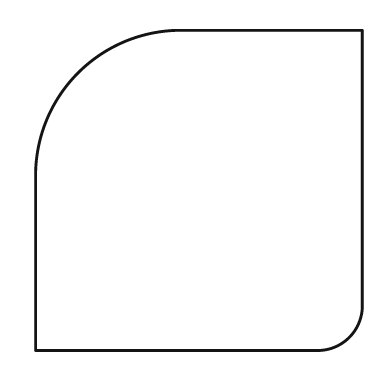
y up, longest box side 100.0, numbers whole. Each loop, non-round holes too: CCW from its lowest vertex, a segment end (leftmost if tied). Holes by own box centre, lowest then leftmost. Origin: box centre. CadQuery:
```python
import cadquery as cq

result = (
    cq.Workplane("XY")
    .moveTo(-50.0, -49.0)
    .lineTo(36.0, -49.0)
    .threePointArc((46.0, -45.0), (50.0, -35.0))
    .lineTo(50.0, 49.0)
    .lineTo(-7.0, 49.0)
    .threePointArc((-37.0, 36.0), (-50.0, 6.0))
    .close()
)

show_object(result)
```